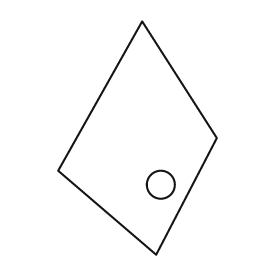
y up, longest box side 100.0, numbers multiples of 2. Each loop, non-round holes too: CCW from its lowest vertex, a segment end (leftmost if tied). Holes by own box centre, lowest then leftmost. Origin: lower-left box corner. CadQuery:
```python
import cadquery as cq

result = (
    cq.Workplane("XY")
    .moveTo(42.0, 0.0)
    .lineTo(68.0, 50.0)
    .lineTo(36.0, 100.0)
    .lineTo(0.0, 36.0)
    .close()
    .moveTo(44.0, 30.0)
    .circle(6.0)
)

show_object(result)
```